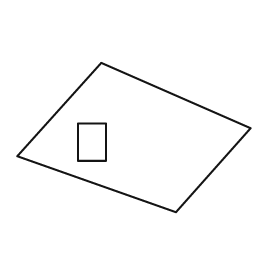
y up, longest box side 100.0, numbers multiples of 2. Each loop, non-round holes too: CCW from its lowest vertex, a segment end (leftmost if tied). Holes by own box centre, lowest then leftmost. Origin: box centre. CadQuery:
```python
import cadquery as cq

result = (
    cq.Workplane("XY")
    .moveTo(18.0, -32.0)
    .lineTo(50.0, 4.0)
    .lineTo(-14.0, 32.0)
    .lineTo(-50.0, -8.0)
    .close()
    .moveTo(-24.0, -10.0)
    .lineTo(-12.0, -10.0)
    .lineTo(-12.0, 6.0)
    .lineTo(-24.0, 6.0)
    .close()
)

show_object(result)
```